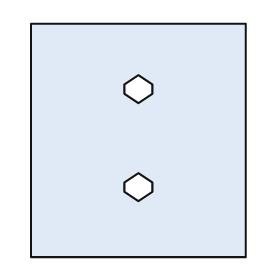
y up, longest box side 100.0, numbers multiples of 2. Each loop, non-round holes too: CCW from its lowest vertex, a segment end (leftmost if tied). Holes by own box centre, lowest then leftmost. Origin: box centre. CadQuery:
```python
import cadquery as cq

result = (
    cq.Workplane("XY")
    .moveTo(-46.0, -50.0)
    .lineTo(46.0, -50.0)
    .lineTo(46.0, 50.0)
    .lineTo(-46.0, 50.0)
    .close()
    .moveTo(0.0, -26.0)
    .lineTo(6.0, -22.0)
    .lineTo(6.0, -18.0)
    .lineTo(0.0, -14.0)
    .lineTo(-6.0, -18.0)
    .lineTo(-6.0, -22.0)
    .close()
    .moveTo(0.0, 16.0)
    .lineTo(6.0, 20.0)
    .lineTo(6.0, 24.0)
    .lineTo(0.0, 28.0)
    .lineTo(-6.0, 24.0)
    .lineTo(-6.0, 20.0)
    .close()
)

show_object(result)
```